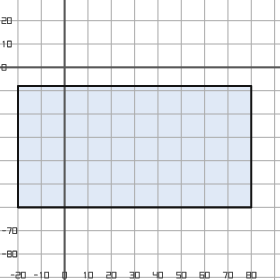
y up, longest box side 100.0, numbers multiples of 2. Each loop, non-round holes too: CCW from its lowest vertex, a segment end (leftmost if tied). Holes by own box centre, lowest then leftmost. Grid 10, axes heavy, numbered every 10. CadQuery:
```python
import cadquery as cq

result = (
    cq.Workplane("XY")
    .moveTo(-20.0, -60.0)
    .lineTo(80.0, -60.0)
    .lineTo(80.0, -8.0)
    .lineTo(-20.0, -8.0)
    .close()
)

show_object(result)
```